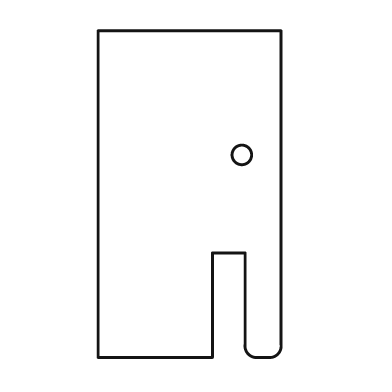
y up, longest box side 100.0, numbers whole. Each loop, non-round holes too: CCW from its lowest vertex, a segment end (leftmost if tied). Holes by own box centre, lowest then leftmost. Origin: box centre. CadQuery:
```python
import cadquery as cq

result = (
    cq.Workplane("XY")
    .moveTo(-28.0, -50.0)
    .lineTo(7.0, -50.0)
    .lineTo(7.0, -18.0)
    .lineTo(17.0, -18.0)
    .lineTo(17.0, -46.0)
    .threePointArc((18.0, -49.0), (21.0, -50.0))
    .lineTo(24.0, -50.0)
    .threePointArc((27.0, -49.0), (28.0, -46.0))
    .lineTo(28.0, 50.0)
    .lineTo(-28.0, 50.0)
    .close()
    .moveTo(16.0, 12.0)
    .circle(3.0)
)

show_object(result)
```